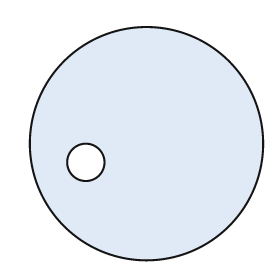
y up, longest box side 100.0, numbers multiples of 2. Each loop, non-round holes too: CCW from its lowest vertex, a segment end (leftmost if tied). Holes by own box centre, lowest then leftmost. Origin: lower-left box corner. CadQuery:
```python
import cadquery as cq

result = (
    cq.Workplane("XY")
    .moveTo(50.0, 50.0)
    .circle(50.0)
    .moveTo(24.0, 42.0)
    .circle(8.0)
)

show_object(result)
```